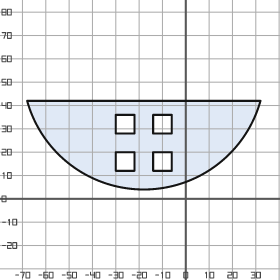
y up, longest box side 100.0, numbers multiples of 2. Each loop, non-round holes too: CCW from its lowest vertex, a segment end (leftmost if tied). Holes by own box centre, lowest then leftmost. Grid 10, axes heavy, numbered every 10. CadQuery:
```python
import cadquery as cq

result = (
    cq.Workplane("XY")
    .moveTo(-68.0, 42.0)
    .threePointArc((-18.0, 4.0), (32.0, 42.0))
    .close()
    .moveTo(-30.0, 12.0)
    .lineTo(-22.0, 12.0)
    .lineTo(-22.0, 20.0)
    .lineTo(-30.0, 20.0)
    .close()
    .moveTo(-14.0, 12.0)
    .lineTo(-6.0, 12.0)
    .lineTo(-6.0, 20.0)
    .lineTo(-14.0, 20.0)
    .close()
    .moveTo(-30.0, 28.0)
    .lineTo(-22.0, 28.0)
    .lineTo(-22.0, 36.0)
    .lineTo(-30.0, 36.0)
    .close()
    .moveTo(-14.0, 28.0)
    .lineTo(-6.0, 28.0)
    .lineTo(-6.0, 36.0)
    .lineTo(-14.0, 36.0)
    .close()
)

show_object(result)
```